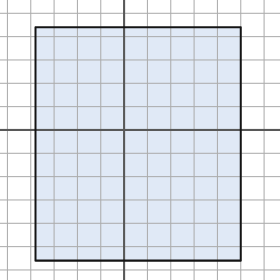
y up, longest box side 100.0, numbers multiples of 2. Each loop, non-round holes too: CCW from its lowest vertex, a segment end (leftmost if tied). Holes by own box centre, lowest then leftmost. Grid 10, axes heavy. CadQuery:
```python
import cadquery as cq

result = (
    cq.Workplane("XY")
    .moveTo(-38.0, -56.0)
    .lineTo(50.0, -56.0)
    .lineTo(50.0, 44.0)
    .lineTo(-38.0, 44.0)
    .close()
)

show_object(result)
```